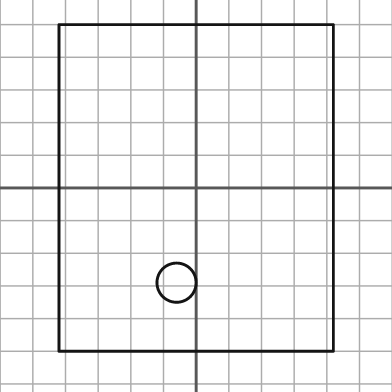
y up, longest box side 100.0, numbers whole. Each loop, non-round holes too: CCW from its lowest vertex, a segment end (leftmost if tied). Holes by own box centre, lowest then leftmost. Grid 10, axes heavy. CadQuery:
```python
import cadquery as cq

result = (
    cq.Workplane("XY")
    .moveTo(-42.0, -50.0)
    .lineTo(42.0, -50.0)
    .lineTo(42.0, 50.0)
    .lineTo(-42.0, 50.0)
    .close()
    .moveTo(-6.0, -29.0)
    .circle(6.0)
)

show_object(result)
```